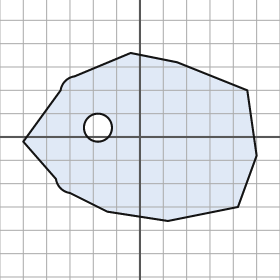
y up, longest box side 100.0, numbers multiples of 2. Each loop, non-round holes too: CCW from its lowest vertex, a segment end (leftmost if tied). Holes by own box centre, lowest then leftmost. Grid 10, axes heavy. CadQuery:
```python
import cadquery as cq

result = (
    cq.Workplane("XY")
    .moveTo(12.0, -36.0)
    .lineTo(42.0, -30.0)
    .lineTo(50.0, -8.0)
    .lineTo(46.0, 20.0)
    .lineTo(16.0, 32.0)
    .lineTo(-4.0, 36.0)
    .lineTo(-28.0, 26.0)
    .threePointArc((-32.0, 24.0), (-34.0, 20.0))
    .lineTo(-50.0, -2.0)
    .lineTo(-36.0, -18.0)
    .threePointArc((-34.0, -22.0), (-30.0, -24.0))
    .lineTo(-14.0, -32.0)
    .close()
    .moveTo(-18.0, 4.0)
    .circle(6.0)
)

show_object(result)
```